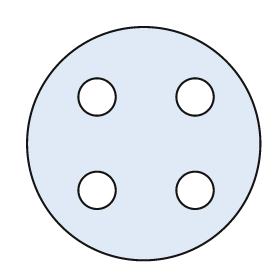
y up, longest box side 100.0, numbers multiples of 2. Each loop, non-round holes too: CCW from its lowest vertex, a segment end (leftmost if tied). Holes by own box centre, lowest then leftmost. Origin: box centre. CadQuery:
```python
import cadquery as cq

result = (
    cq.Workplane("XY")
    .moveTo(0.0, 0.0)
    .circle(50.0)
    .moveTo(-20.0, -20.0)
    .circle(8.0)
    .moveTo(22.0, -20.0)
    .circle(8.0)
    .moveTo(-20.0, 20.0)
    .circle(8.0)
    .moveTo(22.0, 20.0)
    .circle(8.0)
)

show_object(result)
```